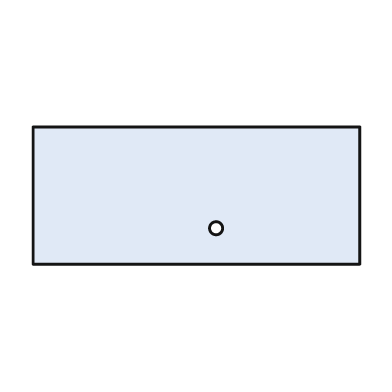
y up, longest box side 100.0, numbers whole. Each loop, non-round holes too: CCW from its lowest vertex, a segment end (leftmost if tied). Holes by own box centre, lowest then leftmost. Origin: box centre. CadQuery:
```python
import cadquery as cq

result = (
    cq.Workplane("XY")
    .moveTo(-50.0, -21.0)
    .lineTo(50.0, -21.0)
    .lineTo(50.0, 21.0)
    .lineTo(-50.0, 21.0)
    .close()
    .moveTo(6.0, -10.0)
    .circle(2.0)
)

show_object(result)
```